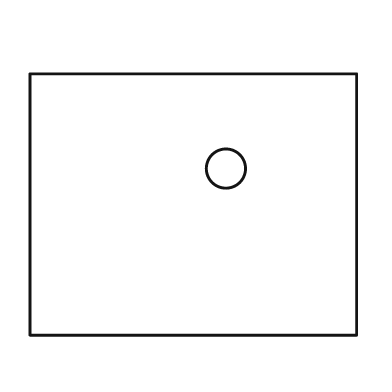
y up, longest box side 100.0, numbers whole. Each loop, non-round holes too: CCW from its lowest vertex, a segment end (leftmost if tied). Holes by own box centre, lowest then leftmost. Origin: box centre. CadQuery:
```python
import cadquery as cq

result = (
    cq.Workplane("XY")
    .moveTo(-50.0, -40.0)
    .lineTo(50.0, -40.0)
    .lineTo(50.0, 40.0)
    .lineTo(-50.0, 40.0)
    .close()
    .moveTo(10.0, 11.0)
    .circle(6.0)
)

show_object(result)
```